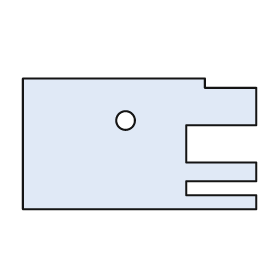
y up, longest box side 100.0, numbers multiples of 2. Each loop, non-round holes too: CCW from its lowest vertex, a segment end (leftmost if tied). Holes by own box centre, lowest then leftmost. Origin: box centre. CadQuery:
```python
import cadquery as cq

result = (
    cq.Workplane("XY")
    .moveTo(-50.0, -28.0)
    .lineTo(50.0, -28.0)
    .lineTo(50.0, -22.0)
    .lineTo(20.0, -22.0)
    .lineTo(20.0, -16.0)
    .lineTo(50.0, -16.0)
    .lineTo(50.0, -8.0)
    .lineTo(20.0, -8.0)
    .lineTo(20.0, 8.0)
    .lineTo(50.0, 8.0)
    .lineTo(50.0, 24.0)
    .lineTo(28.0, 24.0)
    .lineTo(28.0, 28.0)
    .lineTo(-50.0, 28.0)
    .close()
    .moveTo(-6.0, 10.0)
    .circle(4.0)
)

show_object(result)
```